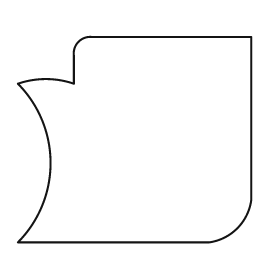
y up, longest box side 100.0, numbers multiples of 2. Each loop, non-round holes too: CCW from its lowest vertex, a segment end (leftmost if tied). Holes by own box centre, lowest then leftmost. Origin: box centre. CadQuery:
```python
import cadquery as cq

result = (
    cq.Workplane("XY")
    .moveTo(-50.0, -44.0)
    .lineTo(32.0, -44.0)
    .threePointArc((44.0, -38.0), (50.0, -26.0))
    .lineTo(50.0, 44.0)
    .lineTo(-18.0, 44.0)
    .threePointArc((-24.0, 42.0), (-26.0, 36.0))
    .lineTo(-26.0, 24.0)
    .threePointArc((-38.0, 26.0), (-50.0, 24.0))
    .threePointArc((-36.0, -10.0), (-50.0, -44.0))
    .close()
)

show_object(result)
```